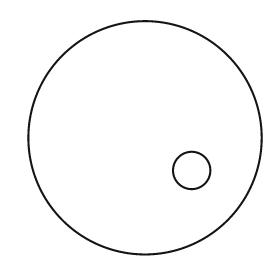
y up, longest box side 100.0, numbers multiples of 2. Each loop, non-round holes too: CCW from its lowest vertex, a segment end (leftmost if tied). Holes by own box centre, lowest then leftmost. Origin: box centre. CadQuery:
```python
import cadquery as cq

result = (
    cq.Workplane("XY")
    .moveTo(0.0, 0.0)
    .circle(50.0)
    .moveTo(20.0, -14.0)
    .circle(8.0)
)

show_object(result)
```